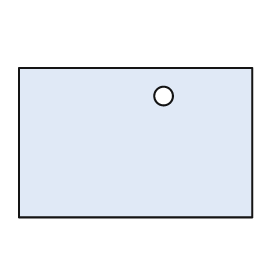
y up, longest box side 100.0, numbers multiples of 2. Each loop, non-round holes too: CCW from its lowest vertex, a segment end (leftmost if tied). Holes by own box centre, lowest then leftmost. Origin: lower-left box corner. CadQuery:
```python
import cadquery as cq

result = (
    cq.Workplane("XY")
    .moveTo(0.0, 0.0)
    .lineTo(100.0, 0.0)
    .lineTo(100.0, 64.0)
    .lineTo(0.0, 64.0)
    .close()
    .moveTo(62.0, 52.0)
    .circle(4.0)
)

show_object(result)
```